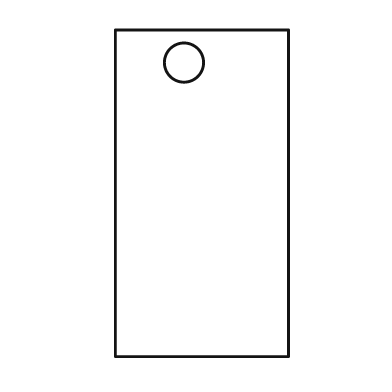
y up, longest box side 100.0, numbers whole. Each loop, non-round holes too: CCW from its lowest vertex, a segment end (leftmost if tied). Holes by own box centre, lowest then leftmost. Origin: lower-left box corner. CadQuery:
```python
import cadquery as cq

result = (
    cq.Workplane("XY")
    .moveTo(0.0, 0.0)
    .lineTo(53.0, 0.0)
    .lineTo(53.0, 100.0)
    .lineTo(0.0, 100.0)
    .close()
    .moveTo(21.0, 90.0)
    .circle(6.0)
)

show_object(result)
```